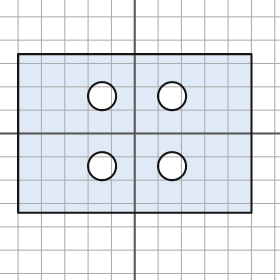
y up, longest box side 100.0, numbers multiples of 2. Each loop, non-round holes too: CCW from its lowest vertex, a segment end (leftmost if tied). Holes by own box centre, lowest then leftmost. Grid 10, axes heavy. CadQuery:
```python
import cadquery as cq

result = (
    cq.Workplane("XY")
    .moveTo(-50.0, -34.0)
    .lineTo(50.0, -34.0)
    .lineTo(50.0, 34.0)
    .lineTo(-50.0, 34.0)
    .close()
    .moveTo(-14.0, -14.0)
    .circle(6.0)
    .moveTo(16.0, -14.0)
    .circle(6.0)
    .moveTo(-14.0, 16.0)
    .circle(6.0)
    .moveTo(16.0, 16.0)
    .circle(6.0)
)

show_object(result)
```